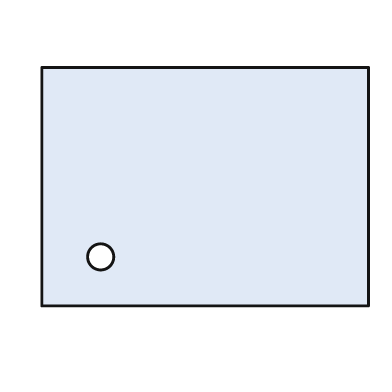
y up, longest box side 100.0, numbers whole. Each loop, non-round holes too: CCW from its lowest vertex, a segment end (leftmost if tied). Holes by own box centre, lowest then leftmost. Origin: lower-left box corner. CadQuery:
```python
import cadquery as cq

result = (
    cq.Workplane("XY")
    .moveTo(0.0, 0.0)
    .lineTo(100.0, 0.0)
    .lineTo(100.0, 73.0)
    .lineTo(0.0, 73.0)
    .close()
    .moveTo(18.0, 15.0)
    .circle(4.0)
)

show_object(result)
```